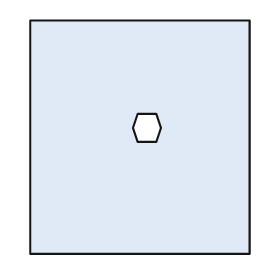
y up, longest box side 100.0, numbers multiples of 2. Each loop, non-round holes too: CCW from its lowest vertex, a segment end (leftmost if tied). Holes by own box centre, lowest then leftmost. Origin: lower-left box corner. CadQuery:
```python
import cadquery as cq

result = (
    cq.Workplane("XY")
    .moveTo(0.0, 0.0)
    .lineTo(94.0, 0.0)
    .lineTo(94.0, 100.0)
    .lineTo(0.0, 100.0)
    .close()
    .moveTo(46.0, 48.0)
    .lineTo(54.0, 48.0)
    .lineTo(56.0, 54.0)
    .lineTo(54.0, 60.0)
    .lineTo(46.0, 60.0)
    .lineTo(44.0, 54.0)
    .close()
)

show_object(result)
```